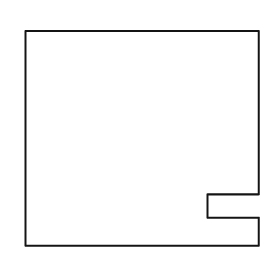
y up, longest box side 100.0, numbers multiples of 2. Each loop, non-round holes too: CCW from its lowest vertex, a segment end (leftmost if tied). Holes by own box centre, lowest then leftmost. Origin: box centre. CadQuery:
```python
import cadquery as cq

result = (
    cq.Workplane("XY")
    .moveTo(-50.0, -46.0)
    .lineTo(50.0, -46.0)
    .lineTo(50.0, -34.0)
    .lineTo(28.0, -34.0)
    .lineTo(28.0, -24.0)
    .lineTo(50.0, -24.0)
    .lineTo(50.0, 46.0)
    .lineTo(-50.0, 46.0)
    .close()
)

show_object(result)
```